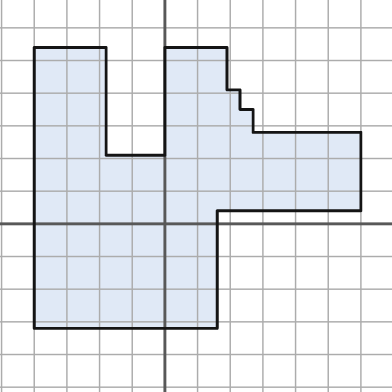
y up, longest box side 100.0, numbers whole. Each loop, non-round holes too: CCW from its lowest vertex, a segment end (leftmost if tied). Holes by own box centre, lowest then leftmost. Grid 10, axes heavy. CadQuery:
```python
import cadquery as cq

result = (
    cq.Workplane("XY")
    .moveTo(-40.0, -32.0)
    .lineTo(16.0, -32.0)
    .lineTo(16.0, 4.0)
    .lineTo(60.0, 4.0)
    .lineTo(60.0, 28.0)
    .lineTo(27.0, 28.0)
    .lineTo(27.0, 35.0)
    .lineTo(23.0, 35.0)
    .lineTo(23.0, 41.0)
    .lineTo(19.0, 41.0)
    .lineTo(19.0, 54.0)
    .lineTo(0.0, 54.0)
    .lineTo(0.0, 21.0)
    .lineTo(-18.0, 21.0)
    .lineTo(-18.0, 54.0)
    .lineTo(-40.0, 54.0)
    .close()
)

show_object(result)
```